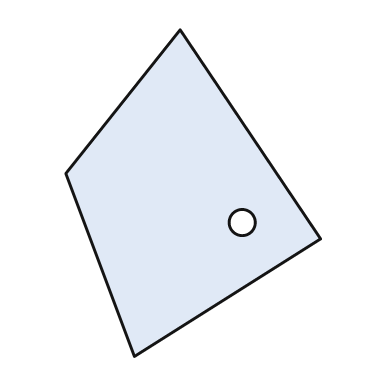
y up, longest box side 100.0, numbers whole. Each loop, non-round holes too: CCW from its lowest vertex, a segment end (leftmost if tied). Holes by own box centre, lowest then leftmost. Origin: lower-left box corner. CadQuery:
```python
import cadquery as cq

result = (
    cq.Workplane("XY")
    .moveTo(21.0, 0.0)
    .lineTo(78.0, 36.0)
    .lineTo(35.0, 100.0)
    .lineTo(0.0, 56.0)
    .close()
    .moveTo(54.0, 41.0)
    .circle(4.0)
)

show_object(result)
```